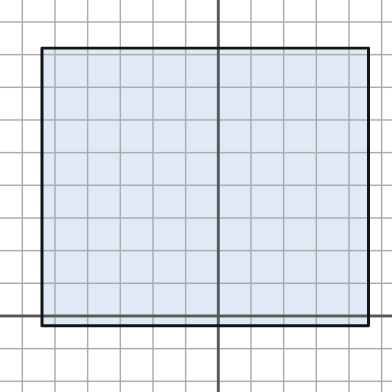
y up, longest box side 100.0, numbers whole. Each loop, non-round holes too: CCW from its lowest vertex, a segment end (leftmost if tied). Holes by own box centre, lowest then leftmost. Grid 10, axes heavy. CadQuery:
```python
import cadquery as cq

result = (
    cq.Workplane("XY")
    .moveTo(-54.0, -3.0)
    .lineTo(46.0, -3.0)
    .lineTo(46.0, 82.0)
    .lineTo(-54.0, 82.0)
    .close()
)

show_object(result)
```